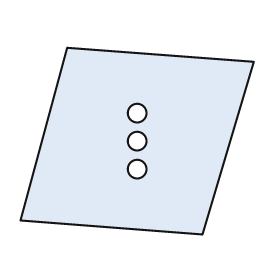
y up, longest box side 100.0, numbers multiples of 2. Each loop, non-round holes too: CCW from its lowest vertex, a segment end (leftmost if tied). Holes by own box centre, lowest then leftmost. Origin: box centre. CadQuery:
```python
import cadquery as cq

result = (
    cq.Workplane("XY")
    .moveTo(28.0, -40.0)
    .lineTo(50.0, 34.0)
    .lineTo(-30.0, 40.0)
    .lineTo(-50.0, -34.0)
    .close()
    .moveTo(0.0, -12.0)
    .circle(4.0)
    .moveTo(0.0, 0.0)
    .circle(4.0)
    .moveTo(0.0, 12.0)
    .circle(4.0)
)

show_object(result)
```